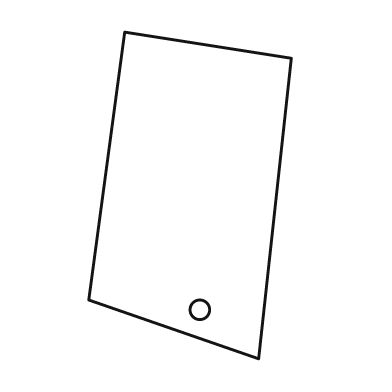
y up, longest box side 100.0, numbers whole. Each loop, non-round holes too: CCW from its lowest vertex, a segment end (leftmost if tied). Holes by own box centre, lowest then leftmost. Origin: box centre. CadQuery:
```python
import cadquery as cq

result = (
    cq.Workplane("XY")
    .moveTo(21.0, -50.0)
    .lineTo(31.0, 42.0)
    .lineTo(-20.0, 50.0)
    .lineTo(-31.0, -32.0)
    .close()
    .moveTo(3.0, -35.0)
    .circle(3.0)
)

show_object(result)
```